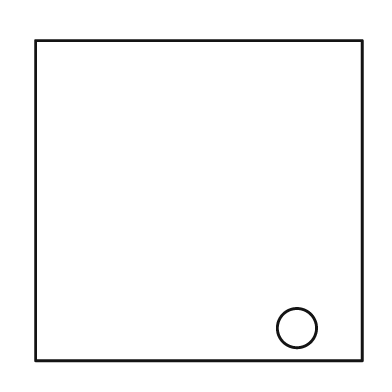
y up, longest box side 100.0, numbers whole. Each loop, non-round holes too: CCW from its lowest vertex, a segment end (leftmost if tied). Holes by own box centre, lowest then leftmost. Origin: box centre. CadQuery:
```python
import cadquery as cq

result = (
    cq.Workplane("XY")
    .moveTo(-50.0, -49.0)
    .lineTo(50.0, -49.0)
    .lineTo(50.0, 49.0)
    .lineTo(-50.0, 49.0)
    .close()
    .moveTo(30.0, -39.0)
    .circle(6.0)
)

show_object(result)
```